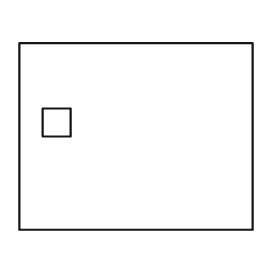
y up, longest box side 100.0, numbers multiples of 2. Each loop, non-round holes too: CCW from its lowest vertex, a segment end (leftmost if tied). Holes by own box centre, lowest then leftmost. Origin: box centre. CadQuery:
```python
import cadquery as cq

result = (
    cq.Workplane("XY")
    .moveTo(-50.0, -40.0)
    .lineTo(50.0, -40.0)
    .lineTo(50.0, 40.0)
    .lineTo(-50.0, 40.0)
    .close()
    .moveTo(-40.0, 0.0)
    .lineTo(-28.0, 0.0)
    .lineTo(-28.0, 12.0)
    .lineTo(-40.0, 12.0)
    .close()
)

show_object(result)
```